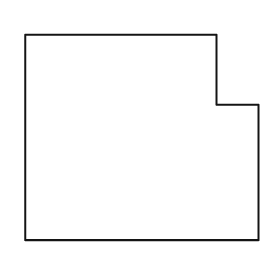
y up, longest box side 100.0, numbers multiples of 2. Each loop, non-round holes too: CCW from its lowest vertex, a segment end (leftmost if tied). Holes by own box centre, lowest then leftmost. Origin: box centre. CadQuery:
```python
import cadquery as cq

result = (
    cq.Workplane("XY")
    .moveTo(-50.0, -44.0)
    .lineTo(50.0, -44.0)
    .lineTo(50.0, 14.0)
    .lineTo(32.0, 14.0)
    .lineTo(32.0, 44.0)
    .lineTo(-50.0, 44.0)
    .close()
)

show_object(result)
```